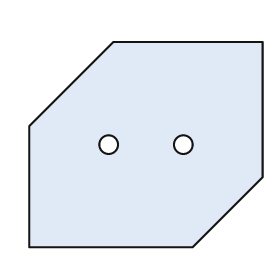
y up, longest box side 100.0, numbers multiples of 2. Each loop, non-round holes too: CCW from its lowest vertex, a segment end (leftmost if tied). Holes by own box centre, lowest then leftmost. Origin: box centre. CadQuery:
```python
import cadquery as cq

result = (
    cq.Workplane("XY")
    .moveTo(-50.0, -44.0)
    .lineTo(20.0, -44.0)
    .lineTo(50.0, -14.0)
    .lineTo(50.0, 44.0)
    .lineTo(-14.0, 44.0)
    .lineTo(-50.0, 8.0)
    .close()
    .moveTo(-16.0, 0.0)
    .circle(4.0)
    .moveTo(16.0, 0.0)
    .circle(4.0)
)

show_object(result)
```